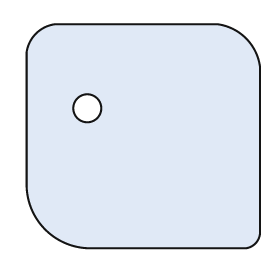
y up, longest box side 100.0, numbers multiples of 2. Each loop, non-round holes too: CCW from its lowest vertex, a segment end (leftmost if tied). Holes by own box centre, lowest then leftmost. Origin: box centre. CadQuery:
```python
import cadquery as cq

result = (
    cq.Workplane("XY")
    .moveTo(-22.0, -48.0)
    .lineTo(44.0, -48.0)
    .threePointArc((48.0, -46.0), (50.0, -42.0))
    .lineTo(50.0, 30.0)
    .threePointArc((44.0, 42.0), (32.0, 48.0))
    .lineTo(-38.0, 48.0)
    .threePointArc((-46.0, 44.0), (-50.0, 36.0))
    .lineTo(-50.0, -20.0)
    .threePointArc((-42.0, -40.0), (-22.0, -48.0))
    .close()
    .moveTo(-24.0, 12.0)
    .circle(6.0)
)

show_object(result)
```